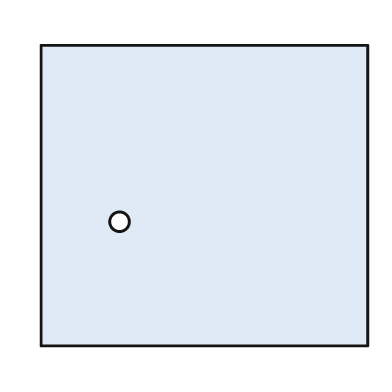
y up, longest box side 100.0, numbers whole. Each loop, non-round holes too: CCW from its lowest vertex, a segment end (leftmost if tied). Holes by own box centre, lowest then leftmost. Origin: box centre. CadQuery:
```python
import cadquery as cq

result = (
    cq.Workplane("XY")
    .moveTo(-50.0, -46.0)
    .lineTo(50.0, -46.0)
    .lineTo(50.0, 46.0)
    .lineTo(-50.0, 46.0)
    .close()
    .moveTo(-26.0, -8.0)
    .circle(3.0)
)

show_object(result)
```